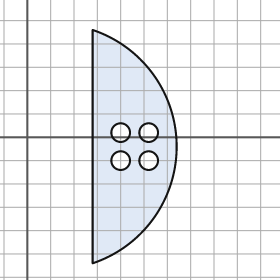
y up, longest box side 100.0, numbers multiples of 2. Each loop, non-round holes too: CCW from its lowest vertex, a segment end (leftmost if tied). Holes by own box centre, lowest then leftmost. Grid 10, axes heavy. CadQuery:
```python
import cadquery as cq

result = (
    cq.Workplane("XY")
    .moveTo(28.0, -54.0)
    .threePointArc((64.0, -4.0), (28.0, 46.0))
    .close()
    .moveTo(40.0, -10.0)
    .circle(4.0)
    .moveTo(52.0, -10.0)
    .circle(4.0)
    .moveTo(40.0, 2.0)
    .circle(4.0)
    .moveTo(52.0, 2.0)
    .circle(4.0)
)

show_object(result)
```